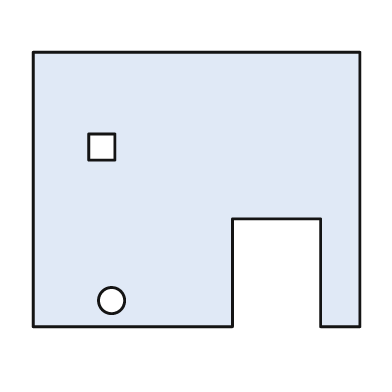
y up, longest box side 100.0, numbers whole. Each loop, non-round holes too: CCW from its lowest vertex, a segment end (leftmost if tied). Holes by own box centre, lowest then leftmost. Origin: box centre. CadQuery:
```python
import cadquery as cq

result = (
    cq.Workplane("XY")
    .moveTo(-50.0, -42.0)
    .lineTo(11.0, -42.0)
    .lineTo(11.0, -9.0)
    .lineTo(38.0, -9.0)
    .lineTo(38.0, -42.0)
    .lineTo(50.0, -42.0)
    .lineTo(50.0, 42.0)
    .lineTo(-50.0, 42.0)
    .close()
    .moveTo(-26.0, -34.0)
    .circle(4.0)
    .moveTo(-33.0, 9.0)
    .lineTo(-25.0, 9.0)
    .lineTo(-25.0, 17.0)
    .lineTo(-33.0, 17.0)
    .close()
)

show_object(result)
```